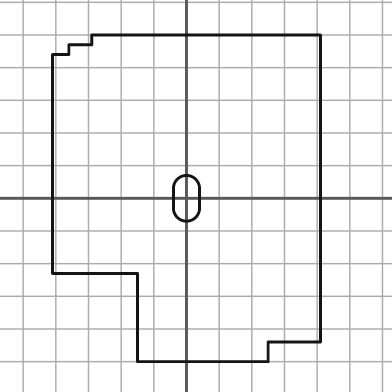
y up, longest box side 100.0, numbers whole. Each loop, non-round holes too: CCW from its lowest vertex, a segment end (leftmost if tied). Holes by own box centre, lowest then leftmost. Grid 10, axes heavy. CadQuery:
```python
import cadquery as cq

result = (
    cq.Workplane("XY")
    .moveTo(-15.0, -50.0)
    .lineTo(25.0, -50.0)
    .lineTo(25.0, -44.0)
    .lineTo(41.0, -44.0)
    .lineTo(41.0, 50.0)
    .lineTo(-29.0, 50.0)
    .lineTo(-29.0, 47.0)
    .lineTo(-36.0, 47.0)
    .lineTo(-36.0, 44.0)
    .lineTo(-41.0, 44.0)
    .lineTo(-41.0, -23.0)
    .lineTo(-15.0, -23.0)
    .close()
    .moveTo(-4.0, -3.0)
    .threePointArc((0.0, -7.0), (4.0, -3.0))
    .lineTo(4.0, 3.0)
    .threePointArc((0.0, 7.0), (-4.0, 3.0))
    .close()
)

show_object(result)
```